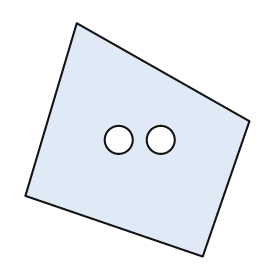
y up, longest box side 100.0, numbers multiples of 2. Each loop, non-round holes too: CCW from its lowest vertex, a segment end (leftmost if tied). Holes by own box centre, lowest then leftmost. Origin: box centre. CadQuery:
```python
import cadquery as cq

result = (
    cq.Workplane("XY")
    .moveTo(28.0, -50.0)
    .lineTo(48.0, 8.0)
    .lineTo(-26.0, 50.0)
    .lineTo(-48.0, -24.0)
    .close()
    .moveTo(-8.0, 0.0)
    .circle(6.0)
    .moveTo(10.0, 0.0)
    .circle(6.0)
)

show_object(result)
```